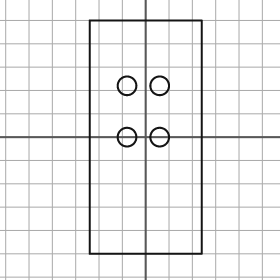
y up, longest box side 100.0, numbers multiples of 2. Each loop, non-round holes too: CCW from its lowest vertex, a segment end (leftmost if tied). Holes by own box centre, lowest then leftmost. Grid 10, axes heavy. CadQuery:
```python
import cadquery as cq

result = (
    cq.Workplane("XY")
    .moveTo(-24.0, -50.0)
    .lineTo(24.0, -50.0)
    .lineTo(24.0, 50.0)
    .lineTo(-24.0, 50.0)
    .close()
    .moveTo(-8.0, 0.0)
    .circle(4.0)
    .moveTo(6.0, 0.0)
    .circle(4.0)
    .moveTo(-8.0, 22.0)
    .circle(4.0)
    .moveTo(6.0, 22.0)
    .circle(4.0)
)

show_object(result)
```